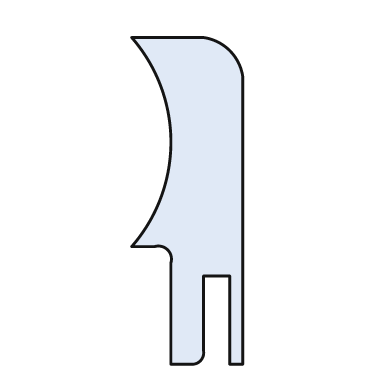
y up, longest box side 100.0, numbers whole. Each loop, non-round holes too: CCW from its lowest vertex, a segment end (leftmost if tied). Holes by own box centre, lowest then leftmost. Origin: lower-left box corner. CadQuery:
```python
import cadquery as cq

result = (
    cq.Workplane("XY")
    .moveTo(12.0, 0.0)
    .lineTo(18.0, 0.0)
    .threePointArc((21.0, 1.0), (22.0, 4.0))
    .lineTo(22.0, 27.0)
    .lineTo(30.0, 27.0)
    .lineTo(30.0, 0.0)
    .lineTo(34.0, 0.0)
    .lineTo(34.0, 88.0)
    .threePointArc((30.0, 96.0), (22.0, 100.0))
    .lineTo(0.0, 100.0)
    .threePointArc((12.0, 68.0), (0.0, 36.0))
    .lineTo(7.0, 36.0)
    .threePointArc((11.0, 35.0), (12.0, 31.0))
    .close()
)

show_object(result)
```